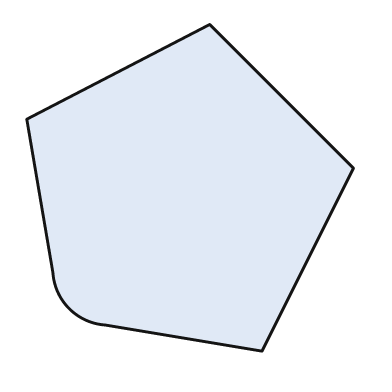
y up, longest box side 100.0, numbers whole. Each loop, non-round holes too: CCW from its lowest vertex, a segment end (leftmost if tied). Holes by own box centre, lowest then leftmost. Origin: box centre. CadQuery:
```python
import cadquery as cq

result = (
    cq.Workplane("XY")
    .moveTo(22.0, -50.0)
    .lineTo(50.0, 6.0)
    .lineTo(6.0, 50.0)
    .lineTo(-50.0, 21.0)
    .lineTo(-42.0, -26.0)
    .threePointArc((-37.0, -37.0), (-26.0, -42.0))
    .close()
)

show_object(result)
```